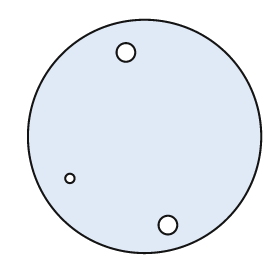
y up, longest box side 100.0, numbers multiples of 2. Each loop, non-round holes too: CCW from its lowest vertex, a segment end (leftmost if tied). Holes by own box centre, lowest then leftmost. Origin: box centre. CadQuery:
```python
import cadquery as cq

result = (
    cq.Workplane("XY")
    .moveTo(0.0, 0.0)
    .circle(50.0)
    .moveTo(10.0, -38.0)
    .circle(4.0)
    .moveTo(-32.0, -18.0)
    .circle(2.0)
    .moveTo(-8.0, 36.0)
    .circle(4.0)
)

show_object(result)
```